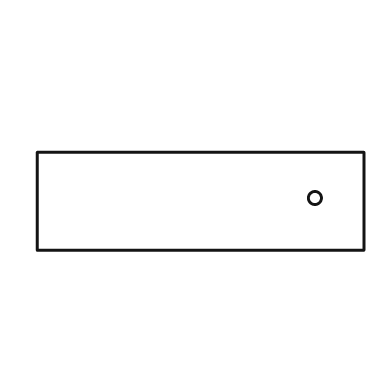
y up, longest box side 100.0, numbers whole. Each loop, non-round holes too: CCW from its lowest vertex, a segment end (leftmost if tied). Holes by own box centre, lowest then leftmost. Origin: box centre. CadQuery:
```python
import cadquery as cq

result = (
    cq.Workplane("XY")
    .moveTo(-50.0, -15.0)
    .lineTo(50.0, -15.0)
    .lineTo(50.0, 15.0)
    .lineTo(-50.0, 15.0)
    .close()
    .moveTo(35.0, 1.0)
    .circle(2.0)
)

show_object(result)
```